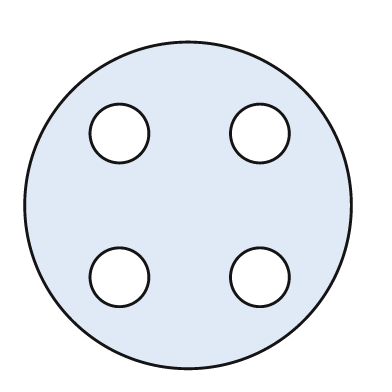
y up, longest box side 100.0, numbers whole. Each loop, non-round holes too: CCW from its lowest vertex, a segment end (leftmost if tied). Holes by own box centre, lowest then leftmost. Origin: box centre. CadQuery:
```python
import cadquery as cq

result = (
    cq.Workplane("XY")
    .moveTo(0.0, 0.0)
    .circle(50.0)
    .moveTo(-21.0, -22.0)
    .circle(9.0)
    .moveTo(22.0, -22.0)
    .circle(9.0)
    .moveTo(-21.0, 22.0)
    .circle(9.0)
    .moveTo(22.0, 22.0)
    .circle(9.0)
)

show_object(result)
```